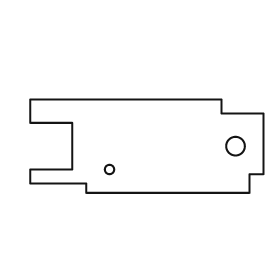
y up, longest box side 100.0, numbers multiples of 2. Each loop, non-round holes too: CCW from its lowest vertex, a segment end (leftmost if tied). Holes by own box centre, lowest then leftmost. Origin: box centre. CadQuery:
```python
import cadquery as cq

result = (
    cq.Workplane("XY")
    .moveTo(-26.0, -20.0)
    .lineTo(44.0, -20.0)
    .lineTo(44.0, -12.0)
    .lineTo(50.0, -12.0)
    .lineTo(50.0, 14.0)
    .lineTo(32.0, 14.0)
    .lineTo(32.0, 20.0)
    .lineTo(-50.0, 20.0)
    .lineTo(-50.0, 10.0)
    .lineTo(-32.0, 10.0)
    .lineTo(-32.0, -10.0)
    .lineTo(-50.0, -10.0)
    .lineTo(-50.0, -16.0)
    .lineTo(-26.0, -16.0)
    .close()
    .moveTo(-16.0, -10.0)
    .circle(2.0)
    .moveTo(38.0, 0.0)
    .circle(4.0)
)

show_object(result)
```